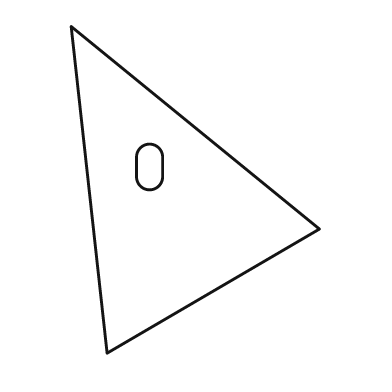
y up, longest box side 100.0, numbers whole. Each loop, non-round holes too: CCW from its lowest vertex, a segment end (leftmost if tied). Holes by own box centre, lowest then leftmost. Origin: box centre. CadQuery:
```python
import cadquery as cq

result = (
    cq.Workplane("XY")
    .moveTo(-27.0, -50.0)
    .lineTo(38.0, -12.0)
    .lineTo(-38.0, 50.0)
    .close()
    .moveTo(-18.0, 4.0)
    .threePointArc((-14.0, 0.0), (-10.0, 4.0))
    .lineTo(-10.0, 10.0)
    .threePointArc((-14.0, 14.0), (-18.0, 10.0))
    .close()
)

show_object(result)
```